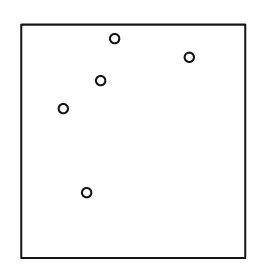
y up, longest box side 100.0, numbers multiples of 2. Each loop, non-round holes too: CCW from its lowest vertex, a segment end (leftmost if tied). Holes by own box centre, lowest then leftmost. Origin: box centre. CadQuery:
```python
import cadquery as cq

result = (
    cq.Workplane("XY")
    .moveTo(-48.0, -50.0)
    .lineTo(48.0, -50.0)
    .lineTo(48.0, 50.0)
    .lineTo(-48.0, 50.0)
    .close()
    .moveTo(-20.0, -22.0)
    .circle(2.0)
    .moveTo(-30.0, 14.0)
    .circle(2.0)
    .moveTo(-14.0, 26.0)
    .circle(2.0)
    .moveTo(24.0, 36.0)
    .circle(2.0)
    .moveTo(-8.0, 44.0)
    .circle(2.0)
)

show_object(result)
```